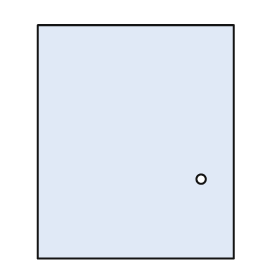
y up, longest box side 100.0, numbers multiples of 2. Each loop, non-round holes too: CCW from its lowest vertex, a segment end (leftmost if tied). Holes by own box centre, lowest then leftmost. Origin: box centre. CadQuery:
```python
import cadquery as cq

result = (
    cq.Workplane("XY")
    .moveTo(-42.0, -50.0)
    .lineTo(42.0, -50.0)
    .lineTo(42.0, 50.0)
    .lineTo(-42.0, 50.0)
    .close()
    .moveTo(28.0, -16.0)
    .circle(2.0)
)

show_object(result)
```